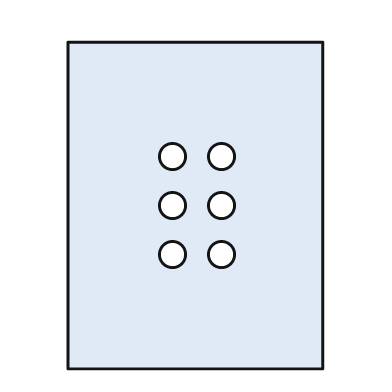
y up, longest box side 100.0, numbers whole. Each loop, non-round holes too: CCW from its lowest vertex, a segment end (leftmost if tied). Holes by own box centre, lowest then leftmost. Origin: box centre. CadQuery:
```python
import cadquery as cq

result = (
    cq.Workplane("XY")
    .moveTo(-39.0, -50.0)
    .lineTo(39.0, -50.0)
    .lineTo(39.0, 50.0)
    .lineTo(-39.0, 50.0)
    .close()
    .moveTo(-7.0, -15.0)
    .circle(4.0)
    .moveTo(8.0, -15.0)
    .circle(4.0)
    .moveTo(-7.0, 0.0)
    .circle(4.0)
    .moveTo(8.0, 0.0)
    .circle(4.0)
    .moveTo(-7.0, 15.0)
    .circle(4.0)
    .moveTo(8.0, 15.0)
    .circle(4.0)
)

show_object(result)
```